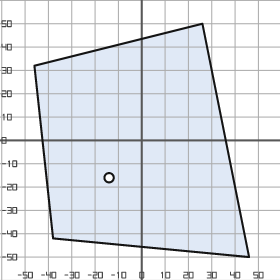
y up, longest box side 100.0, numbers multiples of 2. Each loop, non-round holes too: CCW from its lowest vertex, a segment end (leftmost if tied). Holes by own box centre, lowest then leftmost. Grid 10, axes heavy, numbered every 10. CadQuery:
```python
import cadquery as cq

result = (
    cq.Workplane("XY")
    .moveTo(46.0, -50.0)
    .lineTo(26.0, 50.0)
    .lineTo(-46.0, 32.0)
    .lineTo(-38.0, -42.0)
    .close()
    .moveTo(-14.0, -16.0)
    .circle(2.0)
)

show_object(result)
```